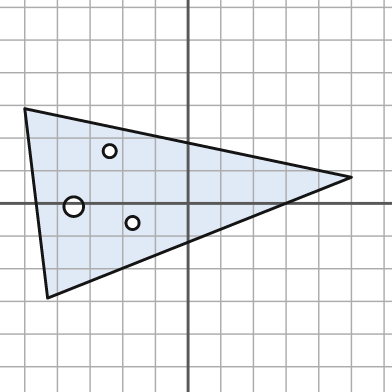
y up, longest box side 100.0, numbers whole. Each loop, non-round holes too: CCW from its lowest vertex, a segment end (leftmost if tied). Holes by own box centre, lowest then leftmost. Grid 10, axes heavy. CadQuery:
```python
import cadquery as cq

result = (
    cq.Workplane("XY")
    .moveTo(-43.0, -29.0)
    .lineTo(50.0, 8.0)
    .lineTo(-50.0, 29.0)
    .close()
    .moveTo(-17.0, -6.0)
    .circle(2.0)
    .moveTo(-35.0, -1.0)
    .circle(3.0)
    .moveTo(-24.0, 16.0)
    .circle(2.0)
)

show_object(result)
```